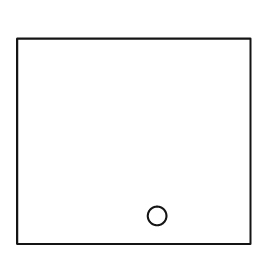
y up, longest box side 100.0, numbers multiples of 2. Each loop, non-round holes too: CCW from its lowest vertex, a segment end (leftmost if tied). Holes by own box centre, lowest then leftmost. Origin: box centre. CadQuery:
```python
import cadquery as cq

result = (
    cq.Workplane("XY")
    .moveTo(-50.0, -44.0)
    .lineTo(50.0, -44.0)
    .lineTo(50.0, 44.0)
    .lineTo(-50.0, 44.0)
    .close()
    .moveTo(10.0, -32.0)
    .circle(4.0)
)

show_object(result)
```